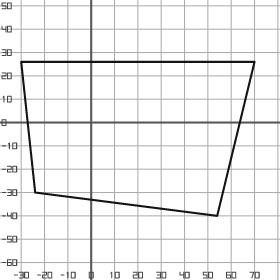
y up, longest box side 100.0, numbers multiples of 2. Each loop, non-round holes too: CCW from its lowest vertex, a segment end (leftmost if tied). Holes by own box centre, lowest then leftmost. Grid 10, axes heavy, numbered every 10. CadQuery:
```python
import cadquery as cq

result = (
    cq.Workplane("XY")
    .moveTo(54.0, -40.0)
    .lineTo(70.0, 26.0)
    .lineTo(-30.0, 26.0)
    .lineTo(-24.0, -30.0)
    .close()
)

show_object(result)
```